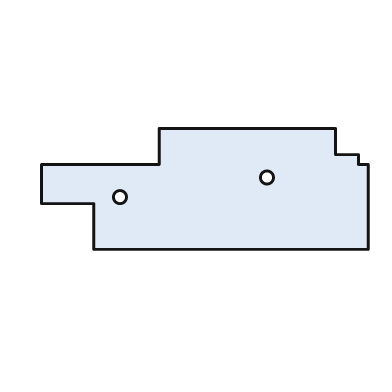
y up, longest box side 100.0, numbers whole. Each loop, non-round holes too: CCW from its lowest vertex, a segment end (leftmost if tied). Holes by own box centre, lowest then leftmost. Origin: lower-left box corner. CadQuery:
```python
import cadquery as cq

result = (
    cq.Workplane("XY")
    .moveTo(16.0, 0.0)
    .lineTo(100.0, 0.0)
    .lineTo(100.0, 26.0)
    .lineTo(97.0, 26.0)
    .lineTo(97.0, 29.0)
    .lineTo(90.0, 29.0)
    .lineTo(90.0, 37.0)
    .lineTo(36.0, 37.0)
    .lineTo(36.0, 26.0)
    .lineTo(0.0, 26.0)
    .lineTo(0.0, 14.0)
    .lineTo(16.0, 14.0)
    .close()
    .moveTo(24.0, 16.0)
    .circle(2.0)
    .moveTo(69.0, 22.0)
    .circle(2.0)
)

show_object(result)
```